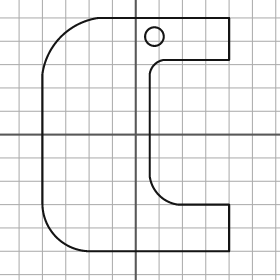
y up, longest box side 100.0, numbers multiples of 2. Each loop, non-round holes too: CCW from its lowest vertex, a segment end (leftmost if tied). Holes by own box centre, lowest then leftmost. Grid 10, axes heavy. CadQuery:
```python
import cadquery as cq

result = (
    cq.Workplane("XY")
    .moveTo(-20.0, -50.0)
    .lineTo(40.0, -50.0)
    .lineTo(40.0, -30.0)
    .lineTo(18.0, -30.0)
    .threePointArc((10.0, -26.0), (6.0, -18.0))
    .lineTo(6.0, 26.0)
    .threePointArc((8.0, 30.0), (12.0, 32.0))
    .lineTo(40.0, 32.0)
    .lineTo(40.0, 50.0)
    .lineTo(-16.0, 50.0)
    .threePointArc((-32.0, 42.0), (-40.0, 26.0))
    .lineTo(-40.0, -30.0)
    .threePointArc((-34.0, -44.0), (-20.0, -50.0))
    .close()
    .moveTo(8.0, 42.0)
    .circle(4.0)
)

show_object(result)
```